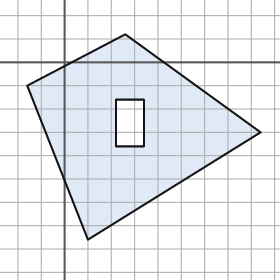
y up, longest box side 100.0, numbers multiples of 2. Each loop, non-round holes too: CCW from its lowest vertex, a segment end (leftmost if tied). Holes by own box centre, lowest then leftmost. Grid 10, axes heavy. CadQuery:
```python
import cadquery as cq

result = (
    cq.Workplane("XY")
    .moveTo(10.0, -76.0)
    .lineTo(84.0, -30.0)
    .lineTo(26.0, 12.0)
    .lineTo(-16.0, -10.0)
    .close()
    .moveTo(22.0, -36.0)
    .lineTo(34.0, -36.0)
    .lineTo(34.0, -16.0)
    .lineTo(22.0, -16.0)
    .close()
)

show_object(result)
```